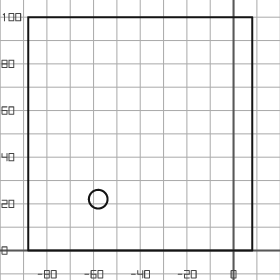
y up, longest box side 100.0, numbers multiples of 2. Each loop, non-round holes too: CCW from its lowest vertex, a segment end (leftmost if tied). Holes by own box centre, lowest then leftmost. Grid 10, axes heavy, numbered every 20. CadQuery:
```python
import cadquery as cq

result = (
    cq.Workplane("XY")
    .moveTo(-88.0, 0.0)
    .lineTo(8.0, 0.0)
    .lineTo(8.0, 100.0)
    .lineTo(-88.0, 100.0)
    .close()
    .moveTo(-58.0, 22.0)
    .circle(4.0)
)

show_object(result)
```